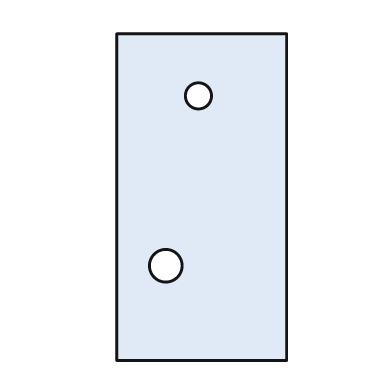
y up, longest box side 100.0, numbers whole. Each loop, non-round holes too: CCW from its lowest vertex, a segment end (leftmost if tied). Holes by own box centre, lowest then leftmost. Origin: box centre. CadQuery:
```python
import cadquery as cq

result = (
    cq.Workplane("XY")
    .moveTo(-26.0, -50.0)
    .lineTo(26.0, -50.0)
    .lineTo(26.0, 50.0)
    .lineTo(-26.0, 50.0)
    .close()
    .moveTo(-11.0, -21.0)
    .circle(5.0)
    .moveTo(-1.0, 31.0)
    .circle(4.0)
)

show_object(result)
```